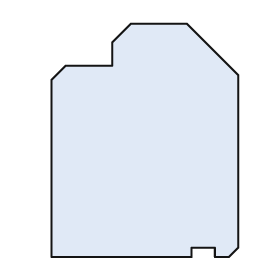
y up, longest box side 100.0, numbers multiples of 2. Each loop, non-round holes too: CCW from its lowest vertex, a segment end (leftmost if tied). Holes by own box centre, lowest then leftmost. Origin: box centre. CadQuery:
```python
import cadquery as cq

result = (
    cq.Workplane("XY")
    .moveTo(-40.0, -50.0)
    .lineTo(20.0, -50.0)
    .lineTo(20.0, -46.0)
    .lineTo(30.0, -46.0)
    .lineTo(30.0, -50.0)
    .lineTo(36.0, -50.0)
    .lineTo(40.0, -46.0)
    .lineTo(40.0, 28.0)
    .lineTo(18.0, 50.0)
    .lineTo(-6.0, 50.0)
    .lineTo(-14.0, 42.0)
    .lineTo(-14.0, 32.0)
    .lineTo(-34.0, 32.0)
    .lineTo(-40.0, 26.0)
    .close()
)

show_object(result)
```